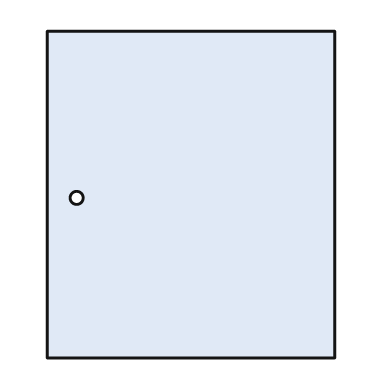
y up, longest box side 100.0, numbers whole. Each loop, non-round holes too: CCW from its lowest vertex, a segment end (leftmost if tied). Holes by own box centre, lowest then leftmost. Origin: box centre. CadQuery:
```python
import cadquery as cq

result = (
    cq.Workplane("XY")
    .moveTo(-44.0, -50.0)
    .lineTo(44.0, -50.0)
    .lineTo(44.0, 50.0)
    .lineTo(-44.0, 50.0)
    .close()
    .moveTo(-35.0, -1.0)
    .circle(2.0)
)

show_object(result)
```